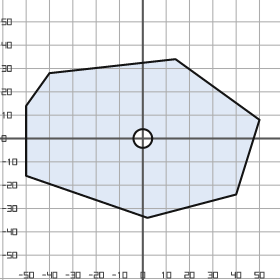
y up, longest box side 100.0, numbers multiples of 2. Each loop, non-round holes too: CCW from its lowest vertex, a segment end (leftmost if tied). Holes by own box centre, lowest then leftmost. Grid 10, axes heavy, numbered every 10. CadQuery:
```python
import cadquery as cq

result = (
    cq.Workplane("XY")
    .moveTo(2.0, -34.0)
    .lineTo(40.0, -24.0)
    .lineTo(50.0, 8.0)
    .lineTo(14.0, 34.0)
    .lineTo(-40.0, 28.0)
    .lineTo(-50.0, 14.0)
    .lineTo(-50.0, -16.0)
    .close()
    .moveTo(0.0, 0.0)
    .circle(4.0)
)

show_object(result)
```